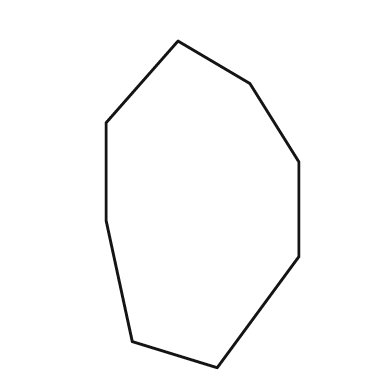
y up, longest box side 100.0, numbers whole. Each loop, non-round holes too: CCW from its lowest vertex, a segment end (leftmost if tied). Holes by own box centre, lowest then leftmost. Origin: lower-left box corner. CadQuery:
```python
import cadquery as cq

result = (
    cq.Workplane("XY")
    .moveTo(34.0, 0.0)
    .lineTo(59.0, 34.0)
    .lineTo(59.0, 63.0)
    .lineTo(44.0, 87.0)
    .lineTo(22.0, 100.0)
    .lineTo(0.0, 75.0)
    .lineTo(0.0, 45.0)
    .lineTo(8.0, 8.0)
    .close()
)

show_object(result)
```